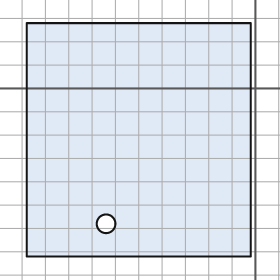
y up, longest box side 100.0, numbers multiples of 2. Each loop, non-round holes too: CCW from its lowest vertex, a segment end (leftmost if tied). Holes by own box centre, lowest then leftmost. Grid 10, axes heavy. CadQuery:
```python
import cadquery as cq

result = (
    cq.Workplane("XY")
    .moveTo(-98.0, -72.0)
    .lineTo(-2.0, -72.0)
    .lineTo(-2.0, 28.0)
    .lineTo(-98.0, 28.0)
    .close()
    .moveTo(-64.0, -58.0)
    .circle(4.0)
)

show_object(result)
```